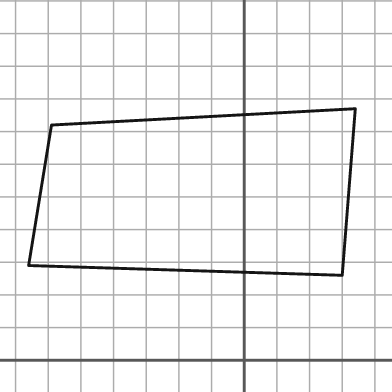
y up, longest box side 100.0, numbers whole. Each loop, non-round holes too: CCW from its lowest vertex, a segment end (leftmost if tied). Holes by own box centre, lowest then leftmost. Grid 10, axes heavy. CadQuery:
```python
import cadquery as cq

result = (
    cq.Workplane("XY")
    .moveTo(30.0, 26.0)
    .lineTo(34.0, 77.0)
    .lineTo(-59.0, 72.0)
    .lineTo(-66.0, 29.0)
    .close()
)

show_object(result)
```